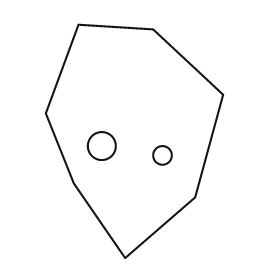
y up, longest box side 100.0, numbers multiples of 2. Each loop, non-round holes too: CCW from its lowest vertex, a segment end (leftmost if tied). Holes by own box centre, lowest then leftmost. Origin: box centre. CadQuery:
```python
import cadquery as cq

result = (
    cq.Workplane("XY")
    .moveTo(-4.0, -50.0)
    .lineTo(26.0, -24.0)
    .lineTo(38.0, 20.0)
    .lineTo(8.0, 48.0)
    .lineTo(-24.0, 50.0)
    .lineTo(-38.0, 12.0)
    .lineTo(-26.0, -18.0)
    .close()
    .moveTo(12.0, -6.0)
    .circle(4.0)
    .moveTo(-14.0, -2.0)
    .circle(6.0)
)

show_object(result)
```